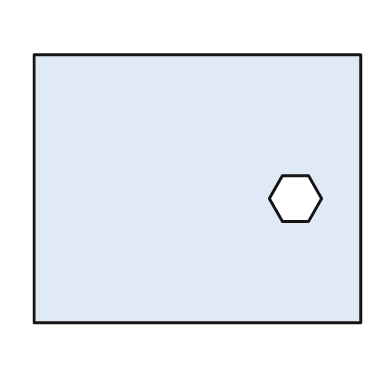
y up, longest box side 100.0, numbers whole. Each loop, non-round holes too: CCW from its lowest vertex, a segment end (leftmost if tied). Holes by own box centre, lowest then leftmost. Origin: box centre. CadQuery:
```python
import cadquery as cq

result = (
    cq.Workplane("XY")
    .moveTo(-50.0, -41.0)
    .lineTo(50.0, -41.0)
    .lineTo(50.0, 41.0)
    .lineTo(-50.0, 41.0)
    .close()
    .moveTo(26.0, -10.0)
    .lineTo(34.0, -10.0)
    .lineTo(38.0, -3.0)
    .lineTo(34.0, 4.0)
    .lineTo(26.0, 4.0)
    .lineTo(22.0, -3.0)
    .close()
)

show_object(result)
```